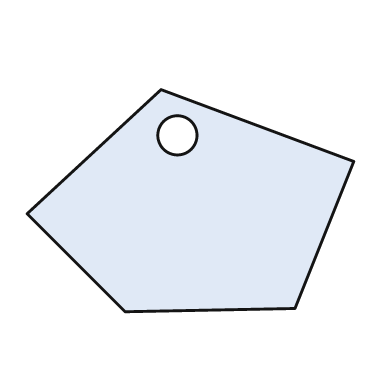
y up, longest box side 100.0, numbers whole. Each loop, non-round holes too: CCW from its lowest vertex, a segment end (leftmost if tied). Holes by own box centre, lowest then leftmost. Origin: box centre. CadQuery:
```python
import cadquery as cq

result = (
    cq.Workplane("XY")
    .moveTo(-20.0, -34.0)
    .lineTo(32.0, -33.0)
    .lineTo(50.0, 12.0)
    .lineTo(-9.0, 34.0)
    .lineTo(-50.0, -4.0)
    .close()
    .moveTo(-4.0, 20.0)
    .circle(6.0)
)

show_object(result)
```